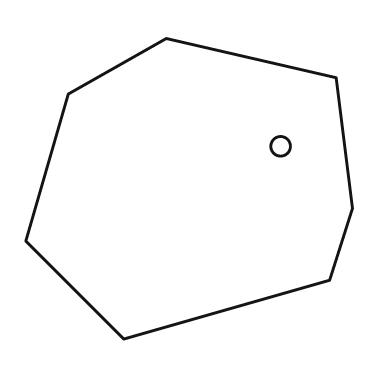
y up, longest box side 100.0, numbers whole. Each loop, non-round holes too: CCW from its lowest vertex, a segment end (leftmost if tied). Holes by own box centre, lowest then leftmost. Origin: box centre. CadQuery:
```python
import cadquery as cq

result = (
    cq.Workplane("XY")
    .moveTo(-20.0, -46.0)
    .lineTo(43.0, -28.0)
    .lineTo(50.0, -6.0)
    .lineTo(45.0, 34.0)
    .lineTo(-7.0, 46.0)
    .lineTo(-37.0, 29.0)
    .lineTo(-50.0, -16.0)
    .close()
    .moveTo(28.0, 13.0)
    .circle(3.0)
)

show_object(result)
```